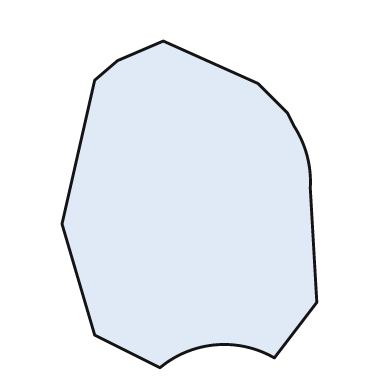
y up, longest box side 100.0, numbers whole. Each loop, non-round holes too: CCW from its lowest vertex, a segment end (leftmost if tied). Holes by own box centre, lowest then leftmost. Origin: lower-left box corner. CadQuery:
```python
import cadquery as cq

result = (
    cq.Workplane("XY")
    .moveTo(30.0, 0.0)
    .threePointArc((47.0, 7.0), (65.0, 3.0))
    .lineTo(78.0, 20.0)
    .lineTo(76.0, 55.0)
    .threePointArc((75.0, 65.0), (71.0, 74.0))
    .lineTo(69.0, 78.0)
    .lineTo(60.0, 87.0)
    .lineTo(31.0, 100.0)
    .lineTo(17.0, 94.0)
    .lineTo(10.0, 88.0)
    .lineTo(0.0, 44.0)
    .lineTo(10.0, 10.0)
    .close()
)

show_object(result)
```